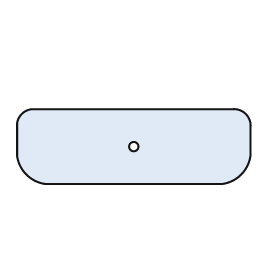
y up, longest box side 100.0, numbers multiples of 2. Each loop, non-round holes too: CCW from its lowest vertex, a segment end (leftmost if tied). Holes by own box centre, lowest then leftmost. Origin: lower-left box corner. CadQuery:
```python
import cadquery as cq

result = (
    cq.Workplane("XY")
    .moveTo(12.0, 0.0)
    .lineTo(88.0, 0.0)
    .threePointArc((96.0, 4.0), (100.0, 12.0))
    .lineTo(100.0, 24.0)
    .threePointArc((98.0, 30.0), (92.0, 32.0))
    .lineTo(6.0, 32.0)
    .threePointArc((2.0, 30.0), (0.0, 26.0))
    .lineTo(0.0, 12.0)
    .threePointArc((4.0, 4.0), (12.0, 0.0))
    .close()
    .moveTo(50.0, 16.0)
    .circle(2.0)
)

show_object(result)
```